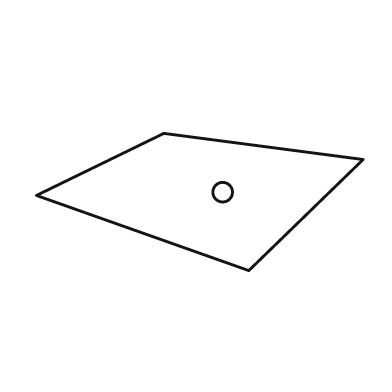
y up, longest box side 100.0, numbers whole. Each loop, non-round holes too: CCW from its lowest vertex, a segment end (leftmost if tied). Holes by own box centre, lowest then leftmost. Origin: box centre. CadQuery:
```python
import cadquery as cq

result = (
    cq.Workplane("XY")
    .moveTo(15.0, -21.0)
    .lineTo(50.0, 13.0)
    .lineTo(-11.0, 21.0)
    .lineTo(-50.0, 2.0)
    .close()
    .moveTo(7.0, 3.0)
    .circle(3.0)
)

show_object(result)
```